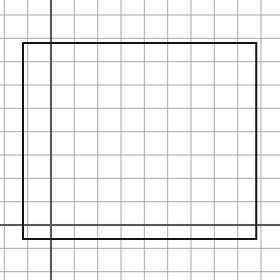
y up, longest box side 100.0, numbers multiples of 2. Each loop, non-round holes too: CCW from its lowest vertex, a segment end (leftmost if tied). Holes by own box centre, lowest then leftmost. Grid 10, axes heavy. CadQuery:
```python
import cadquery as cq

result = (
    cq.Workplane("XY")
    .moveTo(-12.0, -6.0)
    .lineTo(88.0, -6.0)
    .lineTo(88.0, 78.0)
    .lineTo(-12.0, 78.0)
    .close()
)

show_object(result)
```